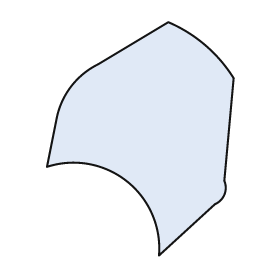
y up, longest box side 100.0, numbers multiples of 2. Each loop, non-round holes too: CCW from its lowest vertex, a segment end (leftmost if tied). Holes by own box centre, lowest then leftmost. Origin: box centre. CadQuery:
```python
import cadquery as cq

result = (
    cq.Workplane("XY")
    .moveTo(8.0, -50.0)
    .lineTo(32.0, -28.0)
    .threePointArc((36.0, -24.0), (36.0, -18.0))
    .lineTo(40.0, 26.0)
    .threePointArc((28.0, 40.0), (12.0, 50.0))
    .lineTo(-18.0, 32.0)
    .threePointArc((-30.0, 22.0), (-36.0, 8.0))
    .lineTo(-40.0, -12.0)
    .threePointArc((-6.0, -18.0), (8.0, -50.0))
    .close()
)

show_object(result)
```